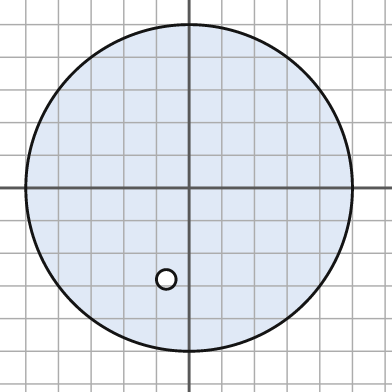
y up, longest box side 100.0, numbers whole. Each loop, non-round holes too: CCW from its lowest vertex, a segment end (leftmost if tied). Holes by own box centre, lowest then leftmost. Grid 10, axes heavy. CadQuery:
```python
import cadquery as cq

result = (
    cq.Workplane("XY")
    .moveTo(0.0, 0.0)
    .circle(50.0)
    .moveTo(-7.0, -28.0)
    .circle(3.0)
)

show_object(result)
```